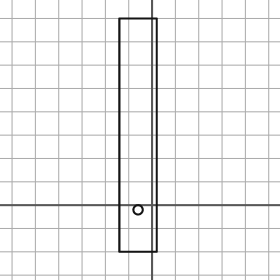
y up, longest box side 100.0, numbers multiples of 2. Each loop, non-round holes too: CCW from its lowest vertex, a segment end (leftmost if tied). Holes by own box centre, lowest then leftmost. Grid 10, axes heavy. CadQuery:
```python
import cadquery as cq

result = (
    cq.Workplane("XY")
    .moveTo(-14.0, -20.0)
    .lineTo(2.0, -20.0)
    .lineTo(2.0, 80.0)
    .lineTo(-14.0, 80.0)
    .close()
    .moveTo(-6.0, -2.0)
    .circle(2.0)
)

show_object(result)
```